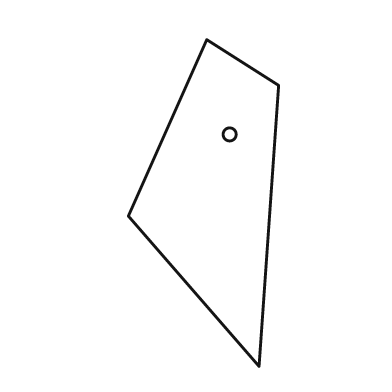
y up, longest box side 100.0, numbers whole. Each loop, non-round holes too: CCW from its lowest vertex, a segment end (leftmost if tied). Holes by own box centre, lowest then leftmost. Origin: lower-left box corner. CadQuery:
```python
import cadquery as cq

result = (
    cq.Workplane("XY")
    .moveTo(40.0, 0.0)
    .lineTo(46.0, 86.0)
    .lineTo(24.0, 100.0)
    .lineTo(0.0, 46.0)
    .close()
    .moveTo(31.0, 71.0)
    .circle(2.0)
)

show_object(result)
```